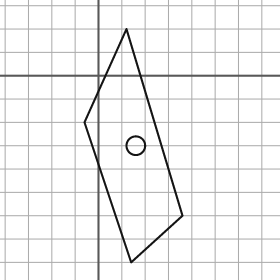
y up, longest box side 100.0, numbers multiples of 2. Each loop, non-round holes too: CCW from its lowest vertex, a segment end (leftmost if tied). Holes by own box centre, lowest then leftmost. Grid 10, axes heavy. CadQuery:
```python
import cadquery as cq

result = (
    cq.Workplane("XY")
    .moveTo(14.0, -80.0)
    .lineTo(36.0, -60.0)
    .lineTo(12.0, 20.0)
    .lineTo(-6.0, -20.0)
    .close()
    .moveTo(16.0, -30.0)
    .circle(4.0)
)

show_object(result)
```